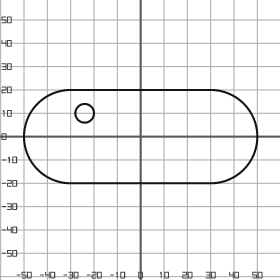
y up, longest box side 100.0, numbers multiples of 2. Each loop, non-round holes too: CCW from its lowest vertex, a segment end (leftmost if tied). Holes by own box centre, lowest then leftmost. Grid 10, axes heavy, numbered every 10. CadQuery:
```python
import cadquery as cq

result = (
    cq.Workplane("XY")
    .moveTo(-30.0, -20.0)
    .lineTo(30.0, -20.0)
    .threePointArc((50.0, 0.0), (30.0, 20.0))
    .lineTo(-30.0, 20.0)
    .threePointArc((-50.0, 0.0), (-30.0, -20.0))
    .close()
    .moveTo(-24.0, 10.0)
    .circle(4.0)
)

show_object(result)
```